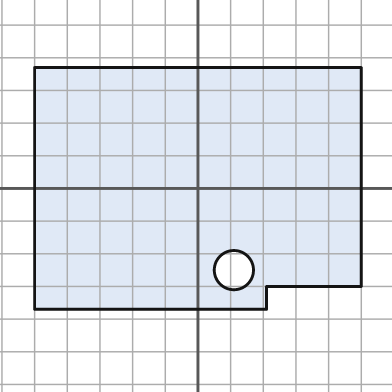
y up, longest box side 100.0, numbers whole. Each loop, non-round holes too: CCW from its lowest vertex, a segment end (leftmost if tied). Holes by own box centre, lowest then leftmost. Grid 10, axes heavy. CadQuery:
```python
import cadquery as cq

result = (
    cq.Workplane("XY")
    .moveTo(-50.0, -37.0)
    .lineTo(21.0, -37.0)
    .lineTo(21.0, -30.0)
    .lineTo(50.0, -30.0)
    .lineTo(50.0, 37.0)
    .lineTo(-50.0, 37.0)
    .close()
    .moveTo(11.0, -25.0)
    .circle(6.0)
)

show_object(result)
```